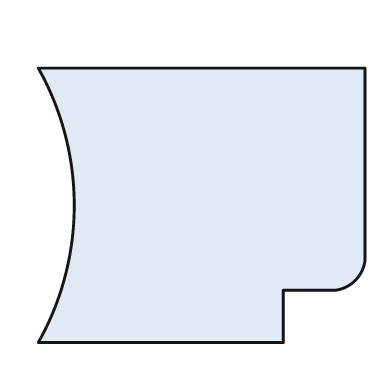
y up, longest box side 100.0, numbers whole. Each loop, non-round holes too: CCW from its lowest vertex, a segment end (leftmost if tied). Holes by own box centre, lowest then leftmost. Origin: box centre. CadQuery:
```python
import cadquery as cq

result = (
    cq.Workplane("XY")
    .moveTo(-50.0, -42.0)
    .lineTo(25.0, -42.0)
    .lineTo(25.0, -26.0)
    .lineTo(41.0, -26.0)
    .threePointArc((47.0, -23.0), (50.0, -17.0))
    .lineTo(50.0, 42.0)
    .lineTo(-50.0, 42.0)
    .threePointArc((-39.0, 0.0), (-50.0, -42.0))
    .close()
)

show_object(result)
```